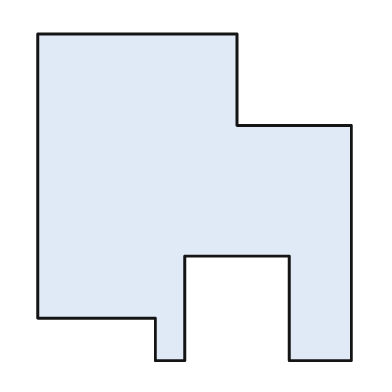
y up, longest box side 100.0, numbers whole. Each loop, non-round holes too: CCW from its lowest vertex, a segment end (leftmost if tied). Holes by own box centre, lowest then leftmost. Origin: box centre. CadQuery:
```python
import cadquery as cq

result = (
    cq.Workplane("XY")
    .moveTo(-12.0, -50.0)
    .lineTo(-3.0, -50.0)
    .lineTo(-3.0, -18.0)
    .lineTo(29.0, -18.0)
    .lineTo(29.0, -50.0)
    .lineTo(48.0, -50.0)
    .lineTo(48.0, 22.0)
    .lineTo(13.0, 22.0)
    .lineTo(13.0, 50.0)
    .lineTo(-48.0, 50.0)
    .lineTo(-48.0, -37.0)
    .lineTo(-12.0, -37.0)
    .close()
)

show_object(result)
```